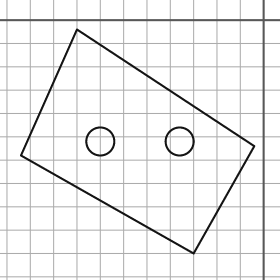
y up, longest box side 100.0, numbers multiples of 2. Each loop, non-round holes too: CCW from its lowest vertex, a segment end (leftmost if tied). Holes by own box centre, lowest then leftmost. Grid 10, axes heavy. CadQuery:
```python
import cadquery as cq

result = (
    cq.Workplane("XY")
    .moveTo(-30.0, -100.0)
    .lineTo(-4.0, -54.0)
    .lineTo(-80.0, -4.0)
    .lineTo(-104.0, -58.0)
    .close()
    .moveTo(-70.0, -52.0)
    .circle(6.0)
    .moveTo(-36.0, -52.0)
    .circle(6.0)
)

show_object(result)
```